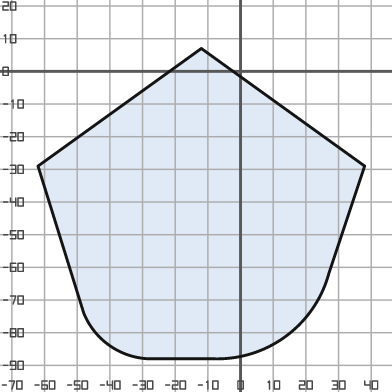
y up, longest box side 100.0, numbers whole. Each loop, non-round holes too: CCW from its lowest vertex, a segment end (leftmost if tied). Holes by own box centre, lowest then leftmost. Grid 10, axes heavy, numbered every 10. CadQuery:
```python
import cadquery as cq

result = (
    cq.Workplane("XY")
    .moveTo(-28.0, -88.0)
    .lineTo(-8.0, -88.0)
    .threePointArc((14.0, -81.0), (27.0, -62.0))
    .lineTo(38.0, -29.0)
    .lineTo(-12.0, 7.0)
    .lineTo(-62.0, -29.0)
    .lineTo(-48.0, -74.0)
    .threePointArc((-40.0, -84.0), (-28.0, -88.0))
    .close()
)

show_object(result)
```